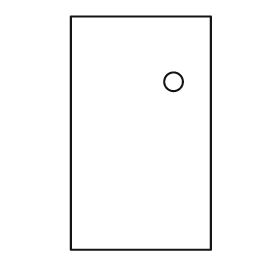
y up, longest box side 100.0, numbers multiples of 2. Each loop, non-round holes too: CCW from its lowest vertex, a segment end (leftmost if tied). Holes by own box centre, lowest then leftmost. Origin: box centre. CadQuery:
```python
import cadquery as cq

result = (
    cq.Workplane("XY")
    .moveTo(-30.0, -50.0)
    .lineTo(30.0, -50.0)
    .lineTo(30.0, 50.0)
    .lineTo(-30.0, 50.0)
    .close()
    .moveTo(14.0, 22.0)
    .circle(4.0)
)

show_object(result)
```